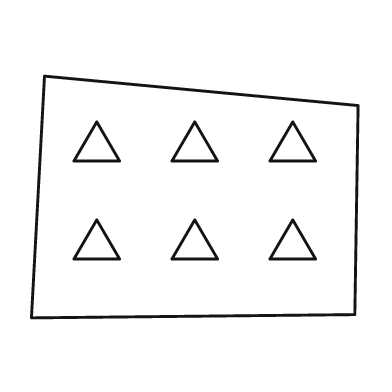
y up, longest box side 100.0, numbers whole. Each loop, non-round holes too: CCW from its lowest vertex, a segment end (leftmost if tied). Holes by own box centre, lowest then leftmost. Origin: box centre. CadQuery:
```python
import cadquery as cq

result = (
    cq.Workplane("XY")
    .moveTo(-50.0, -37.0)
    .lineTo(49.0, -36.0)
    .lineTo(50.0, 28.0)
    .lineTo(-46.0, 37.0)
    .close()
    .moveTo(-37.0, -19.0)
    .lineTo(-23.0, -19.0)
    .lineTo(-30.0, -7.0)
    .close()
    .moveTo(-7.0, -19.0)
    .lineTo(7.0, -19.0)
    .lineTo(0.0, -7.0)
    .close()
    .moveTo(23.0, -19.0)
    .lineTo(37.0, -19.0)
    .lineTo(30.0, -7.0)
    .close()
    .moveTo(-37.0, 11.0)
    .lineTo(-23.0, 11.0)
    .lineTo(-30.0, 23.0)
    .close()
    .moveTo(-7.0, 11.0)
    .lineTo(7.0, 11.0)
    .lineTo(0.0, 23.0)
    .close()
    .moveTo(23.0, 11.0)
    .lineTo(37.0, 11.0)
    .lineTo(30.0, 23.0)
    .close()
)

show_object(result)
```